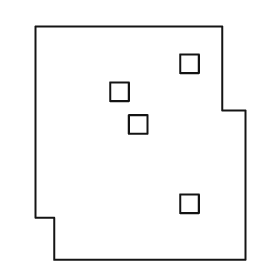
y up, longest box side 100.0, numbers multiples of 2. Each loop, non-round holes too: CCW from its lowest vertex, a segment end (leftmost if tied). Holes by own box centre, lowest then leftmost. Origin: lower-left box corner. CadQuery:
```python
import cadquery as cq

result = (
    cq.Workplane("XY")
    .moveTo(8.0, 0.0)
    .lineTo(90.0, 0.0)
    .lineTo(90.0, 64.0)
    .lineTo(80.0, 64.0)
    .lineTo(80.0, 100.0)
    .lineTo(0.0, 100.0)
    .lineTo(0.0, 18.0)
    .lineTo(8.0, 18.0)
    .close()
    .moveTo(62.0, 20.0)
    .lineTo(70.0, 20.0)
    .lineTo(70.0, 28.0)
    .lineTo(62.0, 28.0)
    .close()
    .moveTo(40.0, 54.0)
    .lineTo(48.0, 54.0)
    .lineTo(48.0, 62.0)
    .lineTo(40.0, 62.0)
    .close()
    .moveTo(32.0, 68.0)
    .lineTo(40.0, 68.0)
    .lineTo(40.0, 76.0)
    .lineTo(32.0, 76.0)
    .close()
    .moveTo(62.0, 80.0)
    .lineTo(70.0, 80.0)
    .lineTo(70.0, 88.0)
    .lineTo(62.0, 88.0)
    .close()
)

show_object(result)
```